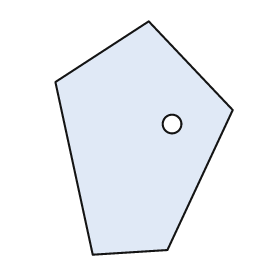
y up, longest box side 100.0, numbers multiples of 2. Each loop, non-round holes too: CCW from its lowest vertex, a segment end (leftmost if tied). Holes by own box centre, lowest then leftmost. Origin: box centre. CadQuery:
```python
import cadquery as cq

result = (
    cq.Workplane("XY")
    .moveTo(-22.0, -50.0)
    .lineTo(10.0, -48.0)
    .lineTo(38.0, 12.0)
    .lineTo(2.0, 50.0)
    .lineTo(-38.0, 24.0)
    .close()
    .moveTo(12.0, 6.0)
    .circle(4.0)
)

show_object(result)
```